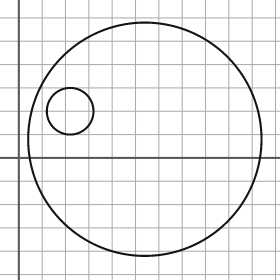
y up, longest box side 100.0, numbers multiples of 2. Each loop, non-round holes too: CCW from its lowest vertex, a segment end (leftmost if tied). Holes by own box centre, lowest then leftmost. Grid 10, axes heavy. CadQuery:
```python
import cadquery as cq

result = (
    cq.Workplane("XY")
    .moveTo(54.0, 8.0)
    .circle(50.0)
    .moveTo(22.0, 20.0)
    .circle(10.0)
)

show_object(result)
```